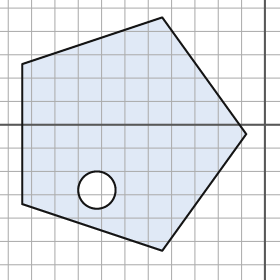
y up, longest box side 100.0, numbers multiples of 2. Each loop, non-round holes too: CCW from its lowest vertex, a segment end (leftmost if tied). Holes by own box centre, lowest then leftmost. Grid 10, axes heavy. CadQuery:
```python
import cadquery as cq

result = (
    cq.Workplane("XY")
    .moveTo(-44.0, -54.0)
    .lineTo(-8.0, -4.0)
    .lineTo(-44.0, 46.0)
    .lineTo(-104.0, 26.0)
    .lineTo(-104.0, -34.0)
    .close()
    .moveTo(-72.0, -28.0)
    .circle(8.0)
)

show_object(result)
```